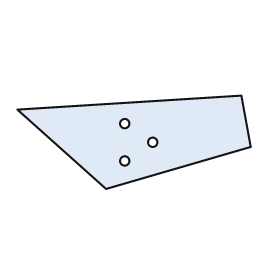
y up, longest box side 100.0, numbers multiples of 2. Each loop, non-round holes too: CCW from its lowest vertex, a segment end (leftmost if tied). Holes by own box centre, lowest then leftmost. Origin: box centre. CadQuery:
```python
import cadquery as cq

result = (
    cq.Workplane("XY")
    .moveTo(-12.0, -20.0)
    .lineTo(50.0, -2.0)
    .lineTo(46.0, 20.0)
    .lineTo(-50.0, 14.0)
    .close()
    .moveTo(-4.0, -8.0)
    .circle(2.0)
    .moveTo(8.0, 0.0)
    .circle(2.0)
    .moveTo(-4.0, 8.0)
    .circle(2.0)
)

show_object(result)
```